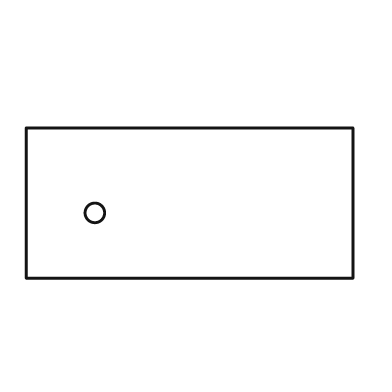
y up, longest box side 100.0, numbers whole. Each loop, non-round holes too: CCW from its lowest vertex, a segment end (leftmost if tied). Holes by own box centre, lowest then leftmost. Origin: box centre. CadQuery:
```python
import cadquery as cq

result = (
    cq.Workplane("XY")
    .moveTo(-50.0, -23.0)
    .lineTo(50.0, -23.0)
    .lineTo(50.0, 23.0)
    .lineTo(-50.0, 23.0)
    .close()
    .moveTo(-29.0, -3.0)
    .circle(3.0)
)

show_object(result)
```